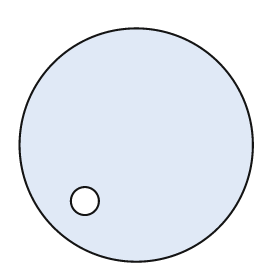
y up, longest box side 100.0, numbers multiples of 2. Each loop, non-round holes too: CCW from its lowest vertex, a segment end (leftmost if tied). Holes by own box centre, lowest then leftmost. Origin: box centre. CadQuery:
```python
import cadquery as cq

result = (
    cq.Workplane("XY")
    .moveTo(0.0, 0.0)
    .circle(50.0)
    .moveTo(-22.0, -24.0)
    .circle(6.0)
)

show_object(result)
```